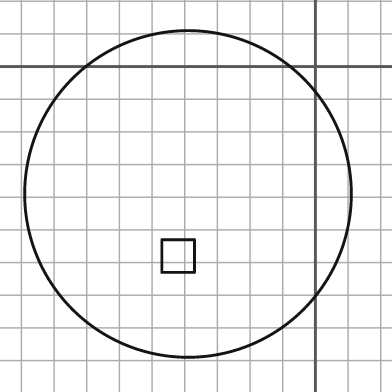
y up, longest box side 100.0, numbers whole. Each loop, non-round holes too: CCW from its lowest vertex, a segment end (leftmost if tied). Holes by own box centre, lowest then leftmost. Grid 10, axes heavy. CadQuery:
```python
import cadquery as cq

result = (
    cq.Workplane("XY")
    .moveTo(-39.0, -39.0)
    .circle(50.0)
    .moveTo(-47.0, -63.0)
    .lineTo(-37.0, -63.0)
    .lineTo(-37.0, -53.0)
    .lineTo(-47.0, -53.0)
    .close()
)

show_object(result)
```